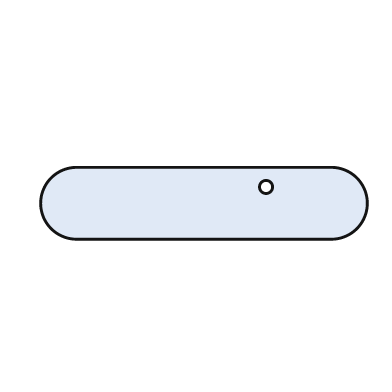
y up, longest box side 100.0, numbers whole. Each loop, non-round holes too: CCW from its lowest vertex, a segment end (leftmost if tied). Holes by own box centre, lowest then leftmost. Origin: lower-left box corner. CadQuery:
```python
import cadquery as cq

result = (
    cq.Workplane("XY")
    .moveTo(11.0, 0.0)
    .lineTo(89.0, 0.0)
    .threePointArc((100.0, 11.0), (89.0, 22.0))
    .lineTo(11.0, 22.0)
    .threePointArc((0.0, 11.0), (11.0, 0.0))
    .close()
    .moveTo(69.0, 16.0)
    .circle(2.0)
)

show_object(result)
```